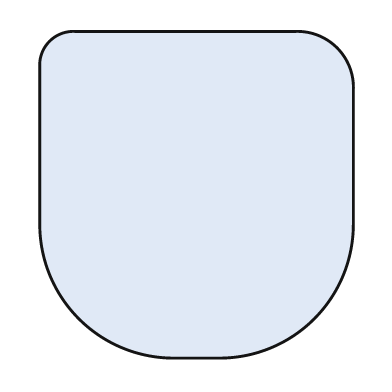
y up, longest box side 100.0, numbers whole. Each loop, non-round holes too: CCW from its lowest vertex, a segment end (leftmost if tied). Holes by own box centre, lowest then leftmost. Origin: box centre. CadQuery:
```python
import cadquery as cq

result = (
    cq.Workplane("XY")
    .moveTo(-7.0, -50.0)
    .lineTo(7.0, -50.0)
    .threePointArc((36.0, -38.0), (48.0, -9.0))
    .lineTo(48.0, 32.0)
    .threePointArc((43.0, 45.0), (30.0, 50.0))
    .lineTo(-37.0, 50.0)
    .threePointArc((-45.0, 47.0), (-48.0, 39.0))
    .lineTo(-48.0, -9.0)
    .threePointArc((-36.0, -38.0), (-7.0, -50.0))
    .close()
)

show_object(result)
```